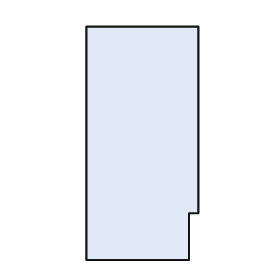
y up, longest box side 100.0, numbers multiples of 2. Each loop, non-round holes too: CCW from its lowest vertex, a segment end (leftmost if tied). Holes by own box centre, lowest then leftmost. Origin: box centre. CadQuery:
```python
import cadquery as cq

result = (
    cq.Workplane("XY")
    .moveTo(-24.0, -50.0)
    .lineTo(20.0, -50.0)
    .lineTo(20.0, -30.0)
    .lineTo(24.0, -30.0)
    .lineTo(24.0, 50.0)
    .lineTo(-24.0, 50.0)
    .close()
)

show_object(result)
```